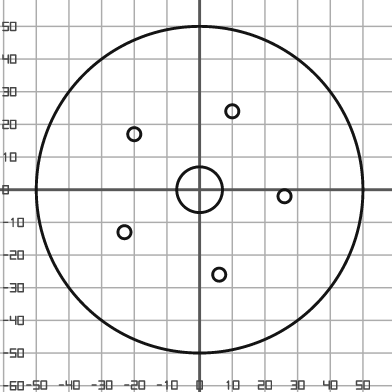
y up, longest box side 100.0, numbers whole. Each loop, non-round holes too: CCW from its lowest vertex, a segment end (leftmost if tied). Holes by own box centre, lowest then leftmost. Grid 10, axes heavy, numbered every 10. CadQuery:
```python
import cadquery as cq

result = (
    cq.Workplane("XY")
    .moveTo(0.0, 0.0)
    .circle(50.0)
    .moveTo(6.0, -26.0)
    .circle(2.0)
    .moveTo(-23.0, -13.0)
    .circle(2.0)
    .moveTo(26.0, -2.0)
    .circle(2.0)
    .moveTo(0.0, 0.0)
    .circle(7.0)
    .moveTo(-20.0, 17.0)
    .circle(2.0)
    .moveTo(10.0, 24.0)
    .circle(2.0)
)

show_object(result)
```